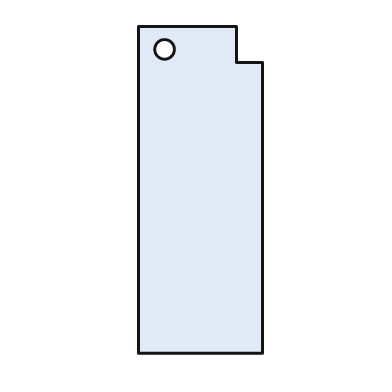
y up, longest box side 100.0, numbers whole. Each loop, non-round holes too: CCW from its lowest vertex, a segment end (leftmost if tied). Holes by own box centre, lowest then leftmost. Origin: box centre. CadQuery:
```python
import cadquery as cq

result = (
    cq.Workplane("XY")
    .moveTo(-19.0, -50.0)
    .lineTo(19.0, -50.0)
    .lineTo(19.0, 39.0)
    .lineTo(11.0, 39.0)
    .lineTo(11.0, 50.0)
    .lineTo(-19.0, 50.0)
    .close()
    .moveTo(-11.0, 43.0)
    .circle(3.0)
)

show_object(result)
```